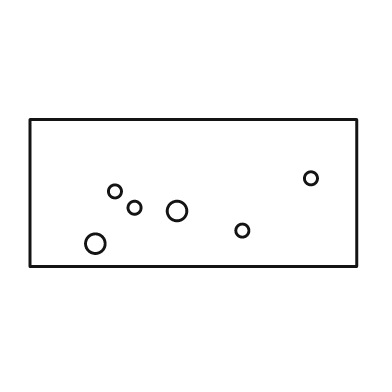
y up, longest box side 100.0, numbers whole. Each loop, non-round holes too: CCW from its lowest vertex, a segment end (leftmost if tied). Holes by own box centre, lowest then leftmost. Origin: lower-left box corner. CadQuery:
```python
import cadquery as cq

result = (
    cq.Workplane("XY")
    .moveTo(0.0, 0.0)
    .lineTo(100.0, 0.0)
    .lineTo(100.0, 45.0)
    .lineTo(0.0, 45.0)
    .close()
    .moveTo(20.0, 7.0)
    .circle(3.0)
    .moveTo(65.0, 11.0)
    .circle(2.0)
    .moveTo(45.0, 17.0)
    .circle(3.0)
    .moveTo(32.0, 18.0)
    .circle(2.0)
    .moveTo(26.0, 23.0)
    .circle(2.0)
    .moveTo(86.0, 27.0)
    .circle(2.0)
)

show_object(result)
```